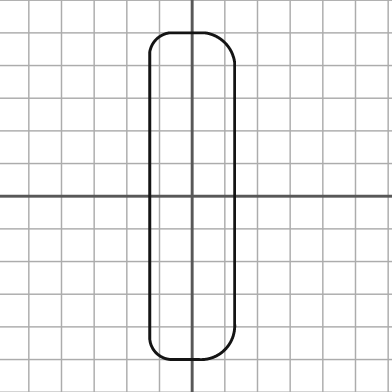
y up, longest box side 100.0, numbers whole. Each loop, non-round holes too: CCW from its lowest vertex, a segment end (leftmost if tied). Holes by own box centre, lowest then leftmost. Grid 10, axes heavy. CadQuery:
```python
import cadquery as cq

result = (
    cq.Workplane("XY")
    .moveTo(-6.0, -50.0)
    .lineTo(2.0, -50.0)
    .threePointArc((10.0, -47.0), (13.0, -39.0))
    .lineTo(13.0, 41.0)
    .threePointArc((10.0, 47.0), (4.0, 50.0))
    .lineTo(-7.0, 50.0)
    .threePointArc((-11.0, 48.0), (-13.0, 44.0))
    .lineTo(-13.0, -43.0)
    .threePointArc((-11.0, -48.0), (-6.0, -50.0))
    .close()
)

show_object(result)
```